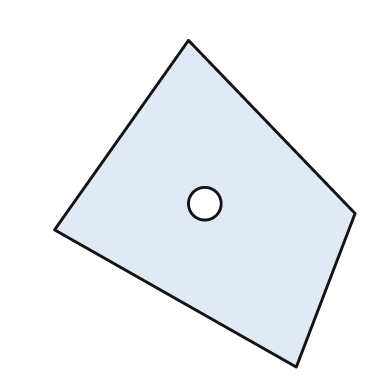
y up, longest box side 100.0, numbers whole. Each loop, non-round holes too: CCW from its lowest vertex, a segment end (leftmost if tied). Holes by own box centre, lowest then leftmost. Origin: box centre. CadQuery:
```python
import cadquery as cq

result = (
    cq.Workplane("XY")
    .moveTo(28.0, -50.0)
    .lineTo(46.0, -3.0)
    .lineTo(-5.0, 50.0)
    .lineTo(-46.0, -8.0)
    .close()
    .moveTo(0.0, 0.0)
    .circle(5.0)
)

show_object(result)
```